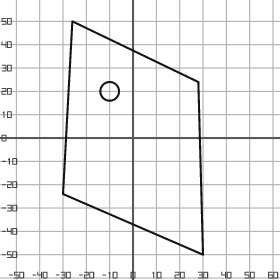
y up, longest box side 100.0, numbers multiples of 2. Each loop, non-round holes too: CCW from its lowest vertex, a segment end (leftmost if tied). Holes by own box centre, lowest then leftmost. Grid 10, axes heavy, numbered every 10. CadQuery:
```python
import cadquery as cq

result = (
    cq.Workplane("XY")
    .moveTo(30.0, -50.0)
    .lineTo(28.0, 24.0)
    .lineTo(-26.0, 50.0)
    .lineTo(-30.0, -24.0)
    .close()
    .moveTo(-10.0, 20.0)
    .circle(4.0)
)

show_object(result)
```